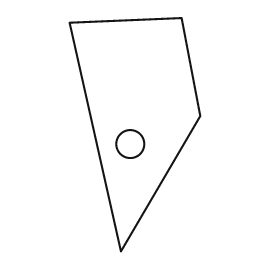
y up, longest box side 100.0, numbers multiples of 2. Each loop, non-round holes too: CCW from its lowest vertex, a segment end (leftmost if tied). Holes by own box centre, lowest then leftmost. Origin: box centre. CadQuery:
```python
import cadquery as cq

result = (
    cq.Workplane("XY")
    .moveTo(-6.0, -50.0)
    .lineTo(28.0, 8.0)
    .lineTo(20.0, 50.0)
    .lineTo(-28.0, 48.0)
    .close()
    .moveTo(-2.0, -4.0)
    .circle(6.0)
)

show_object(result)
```